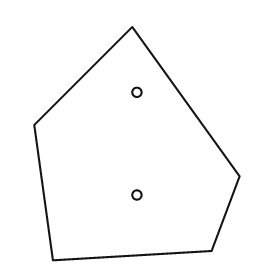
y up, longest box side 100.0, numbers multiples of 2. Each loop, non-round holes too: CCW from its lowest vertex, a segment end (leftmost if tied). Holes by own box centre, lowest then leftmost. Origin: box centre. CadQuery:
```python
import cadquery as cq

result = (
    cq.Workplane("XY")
    .moveTo(-36.0, -50.0)
    .lineTo(32.0, -46.0)
    .lineTo(44.0, -14.0)
    .lineTo(-2.0, 50.0)
    .lineTo(-44.0, 8.0)
    .close()
    .moveTo(0.0, -22.0)
    .circle(2.0)
    .moveTo(0.0, 22.0)
    .circle(2.0)
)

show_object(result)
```